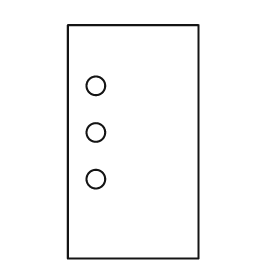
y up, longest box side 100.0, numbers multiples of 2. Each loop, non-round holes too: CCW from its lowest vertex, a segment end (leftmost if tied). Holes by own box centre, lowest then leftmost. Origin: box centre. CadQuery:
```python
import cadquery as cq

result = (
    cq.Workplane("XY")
    .moveTo(-28.0, -50.0)
    .lineTo(28.0, -50.0)
    .lineTo(28.0, 50.0)
    .lineTo(-28.0, 50.0)
    .close()
    .moveTo(-16.0, -16.0)
    .circle(4.0)
    .moveTo(-16.0, 4.0)
    .circle(4.0)
    .moveTo(-16.0, 24.0)
    .circle(4.0)
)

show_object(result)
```